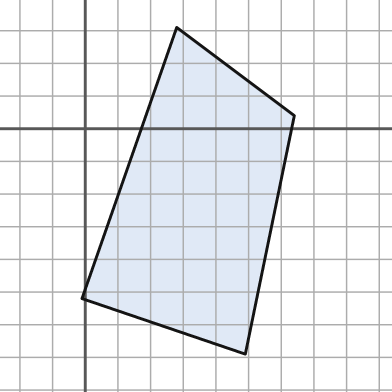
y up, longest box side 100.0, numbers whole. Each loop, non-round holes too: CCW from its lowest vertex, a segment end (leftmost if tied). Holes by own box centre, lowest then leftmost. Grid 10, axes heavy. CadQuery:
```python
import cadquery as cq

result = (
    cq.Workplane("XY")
    .moveTo(49.0, -69.0)
    .lineTo(64.0, 4.0)
    .lineTo(28.0, 31.0)
    .lineTo(-1.0, -52.0)
    .close()
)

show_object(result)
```